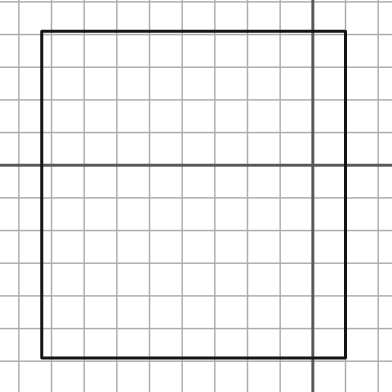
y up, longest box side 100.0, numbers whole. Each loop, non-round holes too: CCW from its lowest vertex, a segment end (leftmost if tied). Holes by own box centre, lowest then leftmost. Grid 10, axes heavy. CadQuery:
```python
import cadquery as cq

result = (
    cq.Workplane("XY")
    .moveTo(-83.0, -59.0)
    .lineTo(10.0, -59.0)
    .lineTo(10.0, 41.0)
    .lineTo(-83.0, 41.0)
    .close()
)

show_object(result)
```